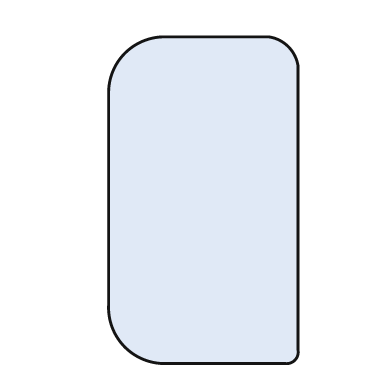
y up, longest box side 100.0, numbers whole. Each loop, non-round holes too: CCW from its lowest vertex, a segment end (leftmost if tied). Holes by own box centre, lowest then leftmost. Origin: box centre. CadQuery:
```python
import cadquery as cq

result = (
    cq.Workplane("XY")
    .moveTo(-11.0, -50.0)
    .lineTo(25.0, -50.0)
    .threePointArc((28.0, -49.0), (29.0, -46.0))
    .lineTo(29.0, 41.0)
    .threePointArc((26.0, 47.0), (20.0, 50.0))
    .lineTo(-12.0, 50.0)
    .threePointArc((-24.0, 45.0), (-29.0, 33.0))
    .lineTo(-29.0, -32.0)
    .threePointArc((-24.0, -45.0), (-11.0, -50.0))
    .close()
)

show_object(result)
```